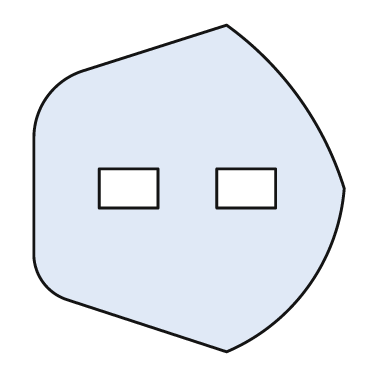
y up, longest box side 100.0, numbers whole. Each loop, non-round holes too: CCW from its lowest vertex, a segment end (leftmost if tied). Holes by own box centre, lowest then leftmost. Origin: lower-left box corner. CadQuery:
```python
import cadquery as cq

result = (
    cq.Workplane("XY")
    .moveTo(59.0, 0.0)
    .threePointArc((84.0, 20.0), (95.0, 50.0))
    .threePointArc((81.0, 78.0), (59.0, 100.0))
    .lineTo(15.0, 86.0)
    .threePointArc((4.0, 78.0), (0.0, 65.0))
    .lineTo(0.0, 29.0)
    .threePointArc((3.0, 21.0), (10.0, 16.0))
    .close()
    .moveTo(20.0, 44.0)
    .lineTo(38.0, 44.0)
    .lineTo(38.0, 56.0)
    .lineTo(20.0, 56.0)
    .close()
    .moveTo(56.0, 44.0)
    .lineTo(74.0, 44.0)
    .lineTo(74.0, 56.0)
    .lineTo(56.0, 56.0)
    .close()
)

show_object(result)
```